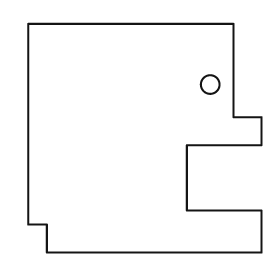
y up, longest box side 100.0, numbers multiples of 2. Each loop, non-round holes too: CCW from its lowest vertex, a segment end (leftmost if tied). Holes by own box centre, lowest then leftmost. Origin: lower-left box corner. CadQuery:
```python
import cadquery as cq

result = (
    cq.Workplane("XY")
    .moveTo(8.0, 0.0)
    .lineTo(100.0, 0.0)
    .lineTo(100.0, 18.0)
    .lineTo(68.0, 18.0)
    .lineTo(68.0, 46.0)
    .lineTo(100.0, 46.0)
    .lineTo(100.0, 58.0)
    .lineTo(88.0, 58.0)
    .lineTo(88.0, 98.0)
    .lineTo(0.0, 98.0)
    .lineTo(0.0, 12.0)
    .lineTo(8.0, 12.0)
    .close()
    .moveTo(78.0, 72.0)
    .circle(4.0)
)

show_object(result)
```